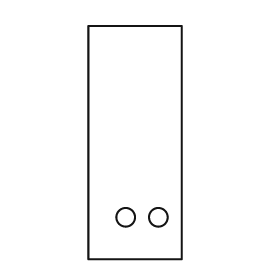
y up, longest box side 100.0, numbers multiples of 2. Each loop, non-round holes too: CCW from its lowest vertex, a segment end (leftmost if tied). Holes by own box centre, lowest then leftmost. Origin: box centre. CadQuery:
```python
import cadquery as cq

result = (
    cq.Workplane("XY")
    .moveTo(-20.0, -50.0)
    .lineTo(20.0, -50.0)
    .lineTo(20.0, 50.0)
    .lineTo(-20.0, 50.0)
    .close()
    .moveTo(-4.0, -32.0)
    .circle(4.0)
    .moveTo(10.0, -32.0)
    .circle(4.0)
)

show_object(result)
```